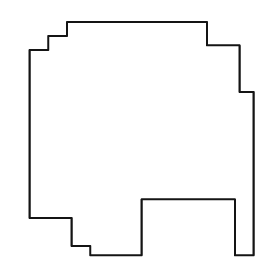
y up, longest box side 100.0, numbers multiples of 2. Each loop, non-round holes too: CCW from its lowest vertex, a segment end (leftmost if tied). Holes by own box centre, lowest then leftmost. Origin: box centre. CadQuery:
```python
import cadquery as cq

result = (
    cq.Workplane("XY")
    .moveTo(-22.0, -50.0)
    .lineTo(0.0, -50.0)
    .lineTo(0.0, -26.0)
    .lineTo(40.0, -26.0)
    .lineTo(40.0, -50.0)
    .lineTo(48.0, -50.0)
    .lineTo(48.0, 20.0)
    .lineTo(42.0, 20.0)
    .lineTo(42.0, 40.0)
    .lineTo(28.0, 40.0)
    .lineTo(28.0, 50.0)
    .lineTo(-32.0, 50.0)
    .lineTo(-32.0, 44.0)
    .lineTo(-40.0, 44.0)
    .lineTo(-40.0, 38.0)
    .lineTo(-48.0, 38.0)
    .lineTo(-48.0, -34.0)
    .lineTo(-30.0, -34.0)
    .lineTo(-30.0, -46.0)
    .lineTo(-22.0, -46.0)
    .close()
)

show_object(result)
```